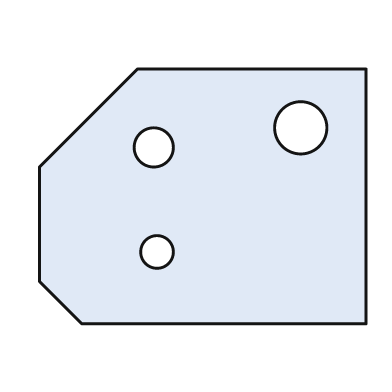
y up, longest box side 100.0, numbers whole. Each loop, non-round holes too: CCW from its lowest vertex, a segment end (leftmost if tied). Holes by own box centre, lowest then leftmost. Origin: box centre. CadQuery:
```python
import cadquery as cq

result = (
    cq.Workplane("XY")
    .moveTo(-37.0, -39.0)
    .lineTo(50.0, -39.0)
    .lineTo(50.0, 39.0)
    .lineTo(-20.0, 39.0)
    .lineTo(-50.0, 9.0)
    .lineTo(-50.0, -26.0)
    .close()
    .moveTo(-14.0, -17.0)
    .circle(5.0)
    .moveTo(-15.0, 15.0)
    .circle(6.0)
    .moveTo(30.0, 21.0)
    .circle(8.0)
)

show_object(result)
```